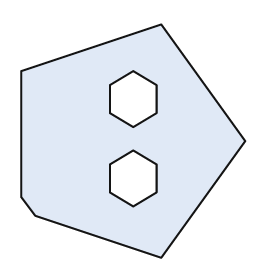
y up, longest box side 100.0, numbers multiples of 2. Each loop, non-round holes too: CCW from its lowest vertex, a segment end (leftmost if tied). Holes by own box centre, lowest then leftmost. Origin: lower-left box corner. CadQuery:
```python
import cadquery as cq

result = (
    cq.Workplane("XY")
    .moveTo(60.0, 0.0)
    .lineTo(96.0, 50.0)
    .lineTo(60.0, 100.0)
    .lineTo(0.0, 80.0)
    .lineTo(0.0, 26.0)
    .lineTo(6.0, 18.0)
    .close()
    .moveTo(48.0, 22.0)
    .lineTo(58.0, 28.0)
    .lineTo(58.0, 40.0)
    .lineTo(48.0, 46.0)
    .lineTo(38.0, 40.0)
    .lineTo(38.0, 28.0)
    .close()
    .moveTo(48.0, 56.0)
    .lineTo(58.0, 62.0)
    .lineTo(58.0, 74.0)
    .lineTo(48.0, 80.0)
    .lineTo(38.0, 74.0)
    .lineTo(38.0, 62.0)
    .close()
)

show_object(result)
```